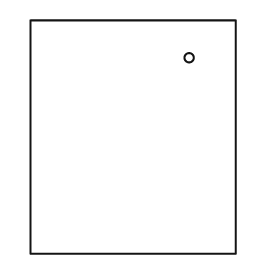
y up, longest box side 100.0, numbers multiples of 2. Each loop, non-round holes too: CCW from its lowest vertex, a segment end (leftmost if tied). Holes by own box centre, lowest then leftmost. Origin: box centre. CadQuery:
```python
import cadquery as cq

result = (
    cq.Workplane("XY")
    .moveTo(-44.0, -50.0)
    .lineTo(44.0, -50.0)
    .lineTo(44.0, 50.0)
    .lineTo(-44.0, 50.0)
    .close()
    .moveTo(24.0, 34.0)
    .circle(2.0)
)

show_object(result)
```